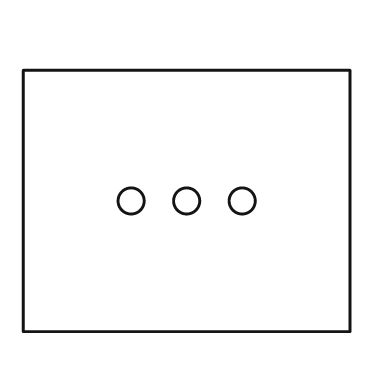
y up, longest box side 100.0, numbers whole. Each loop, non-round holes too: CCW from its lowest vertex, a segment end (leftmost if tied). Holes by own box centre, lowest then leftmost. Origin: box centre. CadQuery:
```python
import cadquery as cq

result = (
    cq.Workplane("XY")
    .moveTo(-50.0, -40.0)
    .lineTo(50.0, -40.0)
    .lineTo(50.0, 40.0)
    .lineTo(-50.0, 40.0)
    .close()
    .moveTo(-17.0, 0.0)
    .circle(4.0)
    .moveTo(0.0, 0.0)
    .circle(4.0)
    .moveTo(17.0, 0.0)
    .circle(4.0)
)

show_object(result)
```